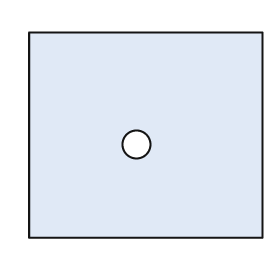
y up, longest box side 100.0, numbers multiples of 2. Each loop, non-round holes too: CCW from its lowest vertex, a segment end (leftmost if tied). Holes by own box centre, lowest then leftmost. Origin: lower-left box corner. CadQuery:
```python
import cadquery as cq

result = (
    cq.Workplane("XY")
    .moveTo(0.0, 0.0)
    .lineTo(100.0, 0.0)
    .lineTo(100.0, 88.0)
    .lineTo(0.0, 88.0)
    .close()
    .moveTo(46.0, 40.0)
    .circle(6.0)
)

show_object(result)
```